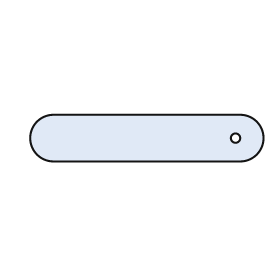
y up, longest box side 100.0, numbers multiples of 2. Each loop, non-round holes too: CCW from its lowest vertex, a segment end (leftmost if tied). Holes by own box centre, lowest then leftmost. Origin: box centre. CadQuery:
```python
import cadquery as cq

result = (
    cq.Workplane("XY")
    .moveTo(-40.0, -10.0)
    .lineTo(40.0, -10.0)
    .threePointArc((50.0, 0.0), (40.0, 10.0))
    .lineTo(-40.0, 10.0)
    .threePointArc((-50.0, 0.0), (-40.0, -10.0))
    .close()
    .moveTo(38.0, 0.0)
    .circle(2.0)
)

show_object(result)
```